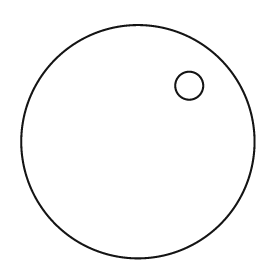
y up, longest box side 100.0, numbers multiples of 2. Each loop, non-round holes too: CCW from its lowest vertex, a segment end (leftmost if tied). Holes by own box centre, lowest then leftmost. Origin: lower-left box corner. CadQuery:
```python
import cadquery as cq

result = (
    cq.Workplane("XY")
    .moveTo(50.0, 50.0)
    .circle(50.0)
    .moveTo(72.0, 74.0)
    .circle(6.0)
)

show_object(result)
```